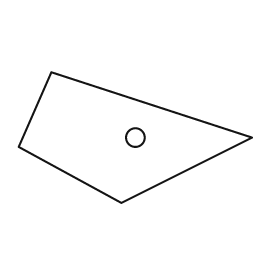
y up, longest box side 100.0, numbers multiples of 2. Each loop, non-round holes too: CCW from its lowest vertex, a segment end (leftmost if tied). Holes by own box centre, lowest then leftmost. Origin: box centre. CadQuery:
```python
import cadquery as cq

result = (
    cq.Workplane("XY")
    .moveTo(-6.0, -28.0)
    .lineTo(50.0, 0.0)
    .lineTo(-36.0, 28.0)
    .lineTo(-50.0, -4.0)
    .close()
    .moveTo(0.0, 0.0)
    .circle(4.0)
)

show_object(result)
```